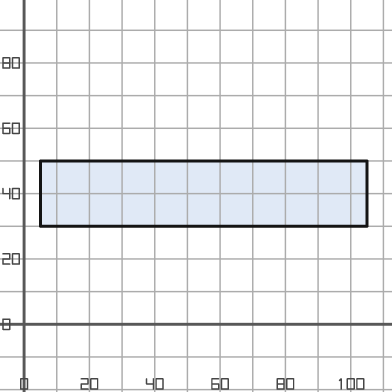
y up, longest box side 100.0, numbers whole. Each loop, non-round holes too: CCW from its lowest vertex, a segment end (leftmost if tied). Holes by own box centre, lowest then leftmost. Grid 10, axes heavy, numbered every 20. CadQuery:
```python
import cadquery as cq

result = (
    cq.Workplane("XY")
    .moveTo(5.0, 30.0)
    .lineTo(105.0, 30.0)
    .lineTo(105.0, 50.0)
    .lineTo(5.0, 50.0)
    .close()
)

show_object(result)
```